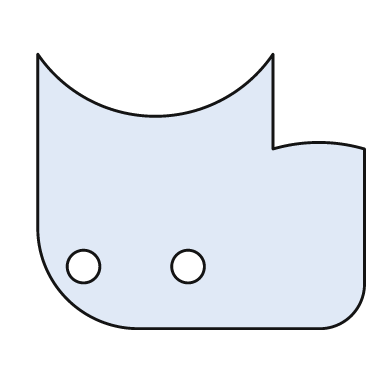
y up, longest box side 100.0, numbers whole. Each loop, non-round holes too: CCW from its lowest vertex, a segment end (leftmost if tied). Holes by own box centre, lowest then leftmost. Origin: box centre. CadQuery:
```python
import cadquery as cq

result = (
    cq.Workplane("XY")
    .moveTo(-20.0, -42.0)
    .lineTo(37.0, -42.0)
    .threePointArc((46.0, -38.0), (50.0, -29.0))
    .lineTo(50.0, 13.0)
    .threePointArc((36.0, 15.0), (22.0, 13.0))
    .lineTo(22.0, 42.0)
    .threePointArc((-14.0, 23.0), (-50.0, 42.0))
    .lineTo(-50.0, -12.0)
    .threePointArc((-41.0, -33.0), (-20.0, -42.0))
    .close()
    .moveTo(-36.0, -23.0)
    .circle(5.0)
    .moveTo(-4.0, -23.0)
    .circle(5.0)
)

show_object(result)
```